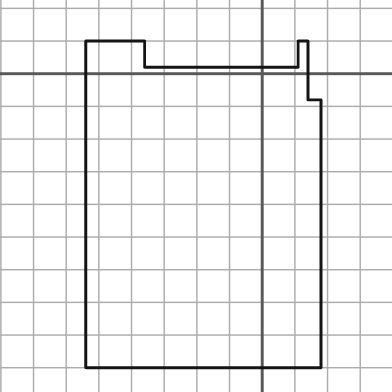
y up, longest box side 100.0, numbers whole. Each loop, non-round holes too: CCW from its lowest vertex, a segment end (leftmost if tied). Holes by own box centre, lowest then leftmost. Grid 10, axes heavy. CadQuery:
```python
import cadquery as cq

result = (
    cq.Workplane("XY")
    .moveTo(-54.0, -90.0)
    .lineTo(18.0, -90.0)
    .lineTo(18.0, -8.0)
    .lineTo(14.0, -8.0)
    .lineTo(14.0, 10.0)
    .lineTo(11.0, 10.0)
    .lineTo(11.0, 2.0)
    .lineTo(-36.0, 2.0)
    .lineTo(-36.0, 10.0)
    .lineTo(-54.0, 10.0)
    .close()
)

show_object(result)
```